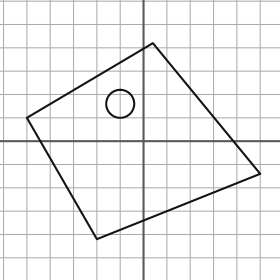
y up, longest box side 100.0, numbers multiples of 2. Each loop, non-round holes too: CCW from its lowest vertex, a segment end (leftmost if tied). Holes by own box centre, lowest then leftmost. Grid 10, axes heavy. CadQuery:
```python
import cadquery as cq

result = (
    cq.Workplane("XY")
    .moveTo(-20.0, -42.0)
    .lineTo(50.0, -14.0)
    .lineTo(4.0, 42.0)
    .lineTo(-50.0, 10.0)
    .close()
    .moveTo(-10.0, 16.0)
    .circle(6.0)
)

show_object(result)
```